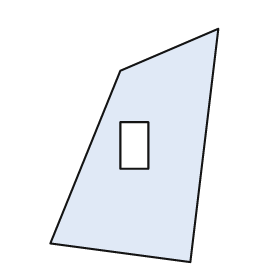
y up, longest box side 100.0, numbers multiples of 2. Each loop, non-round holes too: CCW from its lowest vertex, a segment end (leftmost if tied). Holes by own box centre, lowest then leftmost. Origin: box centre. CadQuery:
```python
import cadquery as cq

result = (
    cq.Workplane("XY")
    .moveTo(24.0, -50.0)
    .lineTo(36.0, 50.0)
    .lineTo(-6.0, 32.0)
    .lineTo(-36.0, -42.0)
    .close()
    .moveTo(-6.0, -10.0)
    .lineTo(6.0, -10.0)
    .lineTo(6.0, 10.0)
    .lineTo(-6.0, 10.0)
    .close()
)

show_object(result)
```